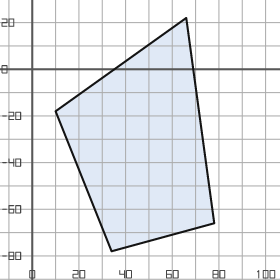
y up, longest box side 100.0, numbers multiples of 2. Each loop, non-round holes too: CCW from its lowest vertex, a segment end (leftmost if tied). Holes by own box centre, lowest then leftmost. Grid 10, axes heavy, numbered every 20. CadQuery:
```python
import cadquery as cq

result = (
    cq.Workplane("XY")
    .moveTo(34.0, -78.0)
    .lineTo(78.0, -66.0)
    .lineTo(66.0, 22.0)
    .lineTo(10.0, -18.0)
    .close()
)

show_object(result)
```